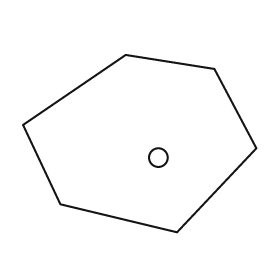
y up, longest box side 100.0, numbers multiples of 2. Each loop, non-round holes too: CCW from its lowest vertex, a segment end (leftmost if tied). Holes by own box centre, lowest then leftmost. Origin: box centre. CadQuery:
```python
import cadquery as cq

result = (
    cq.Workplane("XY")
    .moveTo(16.0, -38.0)
    .lineTo(50.0, -2.0)
    .lineTo(32.0, 32.0)
    .lineTo(-6.0, 38.0)
    .lineTo(-50.0, 8.0)
    .lineTo(-34.0, -26.0)
    .close()
    .moveTo(8.0, -6.0)
    .circle(4.0)
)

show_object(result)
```